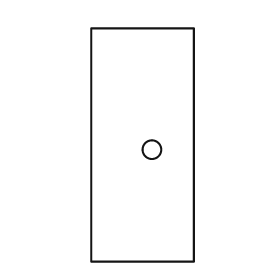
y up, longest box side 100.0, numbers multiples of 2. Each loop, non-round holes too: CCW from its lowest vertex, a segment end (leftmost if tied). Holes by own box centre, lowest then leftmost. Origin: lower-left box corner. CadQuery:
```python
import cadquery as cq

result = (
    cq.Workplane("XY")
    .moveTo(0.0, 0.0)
    .lineTo(44.0, 0.0)
    .lineTo(44.0, 100.0)
    .lineTo(0.0, 100.0)
    .close()
    .moveTo(26.0, 48.0)
    .circle(4.0)
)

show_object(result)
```